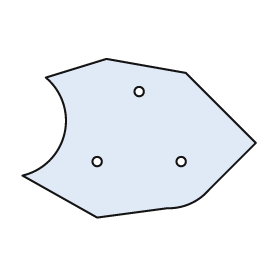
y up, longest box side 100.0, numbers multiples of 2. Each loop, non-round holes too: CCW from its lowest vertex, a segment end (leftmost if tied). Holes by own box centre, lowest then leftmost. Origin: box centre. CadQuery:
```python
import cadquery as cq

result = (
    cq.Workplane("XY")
    .moveTo(-18.0, -34.0)
    .lineTo(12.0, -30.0)
    .threePointArc((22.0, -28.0), (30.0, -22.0))
    .lineTo(50.0, -2.0)
    .lineTo(20.0, 28.0)
    .lineTo(-14.0, 34.0)
    .lineTo(-40.0, 26.0)
    .threePointArc((-32.0, 2.0), (-50.0, -16.0))
    .close()
    .moveTo(-18.0, -10.0)
    .circle(2.0)
    .moveTo(18.0, -10.0)
    .circle(2.0)
    .moveTo(0.0, 20.0)
    .circle(2.0)
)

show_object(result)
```